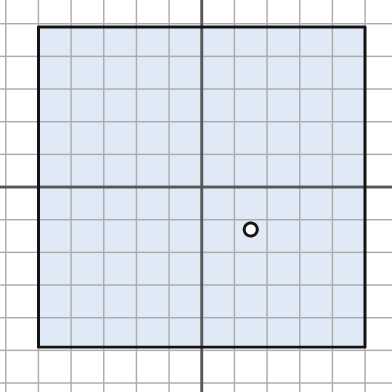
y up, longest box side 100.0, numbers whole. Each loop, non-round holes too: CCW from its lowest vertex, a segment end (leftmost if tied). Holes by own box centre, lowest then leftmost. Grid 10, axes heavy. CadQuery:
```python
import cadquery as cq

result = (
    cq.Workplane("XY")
    .moveTo(-50.0, -49.0)
    .lineTo(50.0, -49.0)
    .lineTo(50.0, 49.0)
    .lineTo(-50.0, 49.0)
    .close()
    .moveTo(15.0, -13.0)
    .circle(2.0)
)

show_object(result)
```